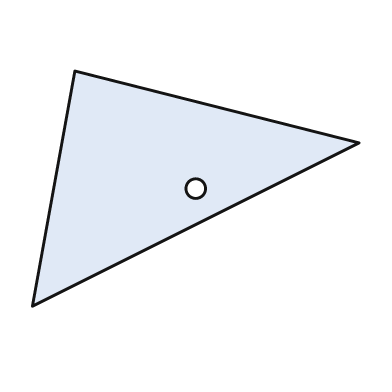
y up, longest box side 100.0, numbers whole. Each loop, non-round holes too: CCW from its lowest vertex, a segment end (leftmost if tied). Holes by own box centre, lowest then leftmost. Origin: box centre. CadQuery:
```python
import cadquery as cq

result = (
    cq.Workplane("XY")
    .moveTo(-50.0, -36.0)
    .lineTo(50.0, 14.0)
    .lineTo(-37.0, 36.0)
    .close()
    .moveTo(0.0, 0.0)
    .circle(3.0)
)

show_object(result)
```